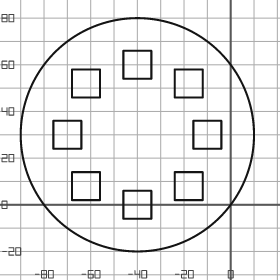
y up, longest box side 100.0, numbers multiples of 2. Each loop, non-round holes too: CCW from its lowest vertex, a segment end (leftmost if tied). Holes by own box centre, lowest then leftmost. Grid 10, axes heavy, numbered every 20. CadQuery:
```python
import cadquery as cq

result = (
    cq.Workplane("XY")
    .moveTo(-40.0, 30.0)
    .circle(50.0)
    .moveTo(-46.0, -6.0)
    .lineTo(-34.0, -6.0)
    .lineTo(-34.0, 6.0)
    .lineTo(-46.0, 6.0)
    .close()
    .moveTo(-68.0, 2.0)
    .lineTo(-56.0, 2.0)
    .lineTo(-56.0, 14.0)
    .lineTo(-68.0, 14.0)
    .close()
    .moveTo(-24.0, 2.0)
    .lineTo(-12.0, 2.0)
    .lineTo(-12.0, 14.0)
    .lineTo(-24.0, 14.0)
    .close()
    .moveTo(-76.0, 24.0)
    .lineTo(-64.0, 24.0)
    .lineTo(-64.0, 36.0)
    .lineTo(-76.0, 36.0)
    .close()
    .moveTo(-16.0, 24.0)
    .lineTo(-4.0, 24.0)
    .lineTo(-4.0, 36.0)
    .lineTo(-16.0, 36.0)
    .close()
    .moveTo(-68.0, 46.0)
    .lineTo(-56.0, 46.0)
    .lineTo(-56.0, 58.0)
    .lineTo(-68.0, 58.0)
    .close()
    .moveTo(-24.0, 46.0)
    .lineTo(-12.0, 46.0)
    .lineTo(-12.0, 58.0)
    .lineTo(-24.0, 58.0)
    .close()
    .moveTo(-46.0, 54.0)
    .lineTo(-34.0, 54.0)
    .lineTo(-34.0, 66.0)
    .lineTo(-46.0, 66.0)
    .close()
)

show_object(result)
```